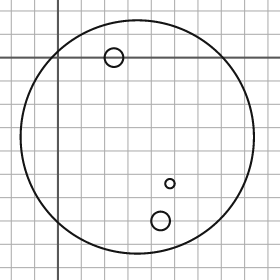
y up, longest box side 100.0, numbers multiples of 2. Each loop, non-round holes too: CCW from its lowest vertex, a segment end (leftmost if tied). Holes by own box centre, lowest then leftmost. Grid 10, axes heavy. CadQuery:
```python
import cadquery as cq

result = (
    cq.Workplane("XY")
    .moveTo(34.0, -34.0)
    .circle(50.0)
    .moveTo(44.0, -70.0)
    .circle(4.0)
    .moveTo(48.0, -54.0)
    .circle(2.0)
    .moveTo(24.0, 0.0)
    .circle(4.0)
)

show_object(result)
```